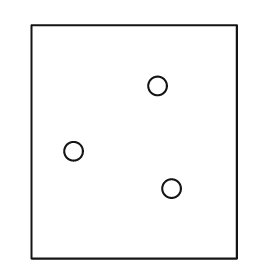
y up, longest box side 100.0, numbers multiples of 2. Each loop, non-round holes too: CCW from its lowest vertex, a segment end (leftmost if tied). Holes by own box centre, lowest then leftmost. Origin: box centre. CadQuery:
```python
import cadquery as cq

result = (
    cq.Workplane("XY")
    .moveTo(-44.0, -50.0)
    .lineTo(44.0, -50.0)
    .lineTo(44.0, 50.0)
    .lineTo(-44.0, 50.0)
    .close()
    .moveTo(16.0, -20.0)
    .circle(4.0)
    .moveTo(-26.0, -4.0)
    .circle(4.0)
    .moveTo(10.0, 24.0)
    .circle(4.0)
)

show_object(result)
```